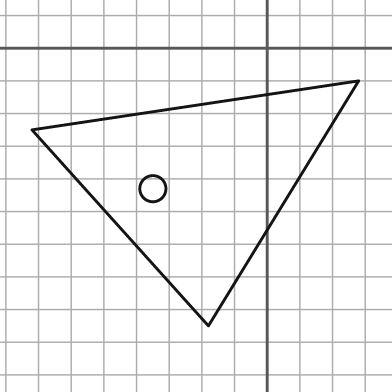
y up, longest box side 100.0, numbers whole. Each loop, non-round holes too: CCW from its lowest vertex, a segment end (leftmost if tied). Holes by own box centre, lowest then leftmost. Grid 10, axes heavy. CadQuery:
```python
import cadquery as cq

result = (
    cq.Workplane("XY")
    .moveTo(-18.0, -85.0)
    .lineTo(28.0, -10.0)
    .lineTo(-72.0, -25.0)
    .close()
    .moveTo(-35.0, -43.0)
    .circle(4.0)
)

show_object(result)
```